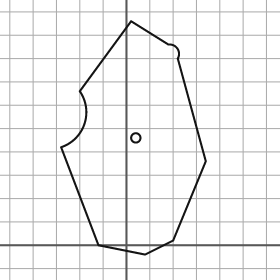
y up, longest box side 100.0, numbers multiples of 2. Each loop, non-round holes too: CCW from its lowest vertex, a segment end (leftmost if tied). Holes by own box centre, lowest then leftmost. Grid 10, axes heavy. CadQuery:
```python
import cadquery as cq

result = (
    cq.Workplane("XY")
    .moveTo(8.0, -4.0)
    .lineTo(20.0, 2.0)
    .lineTo(34.0, 36.0)
    .lineTo(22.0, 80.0)
    .threePointArc((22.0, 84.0), (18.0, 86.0))
    .lineTo(2.0, 96.0)
    .lineTo(-20.0, 66.0)
    .threePointArc((-18.0, 52.0), (-28.0, 42.0))
    .lineTo(-12.0, 0.0)
    .close()
    .moveTo(4.0, 46.0)
    .circle(2.0)
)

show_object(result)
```